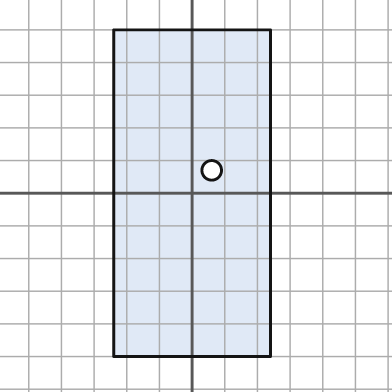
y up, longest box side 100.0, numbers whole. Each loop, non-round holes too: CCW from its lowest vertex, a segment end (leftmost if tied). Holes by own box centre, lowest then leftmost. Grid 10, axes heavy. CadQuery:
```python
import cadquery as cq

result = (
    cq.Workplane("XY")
    .moveTo(-24.0, -50.0)
    .lineTo(24.0, -50.0)
    .lineTo(24.0, 50.0)
    .lineTo(-24.0, 50.0)
    .close()
    .moveTo(6.0, 7.0)
    .circle(3.0)
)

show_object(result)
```